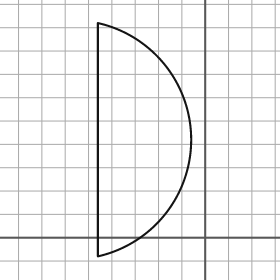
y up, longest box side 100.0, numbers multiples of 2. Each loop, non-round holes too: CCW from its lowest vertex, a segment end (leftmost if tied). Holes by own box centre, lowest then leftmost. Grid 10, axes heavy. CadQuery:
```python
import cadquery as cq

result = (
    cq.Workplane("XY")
    .moveTo(-46.0, -8.0)
    .threePointArc((-6.0, 42.0), (-46.0, 92.0))
    .close()
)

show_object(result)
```